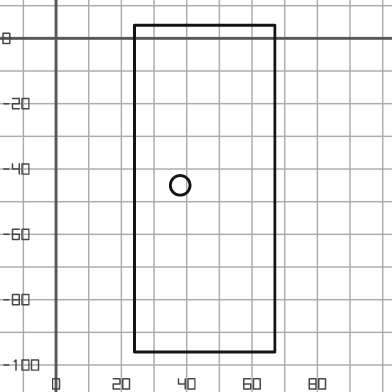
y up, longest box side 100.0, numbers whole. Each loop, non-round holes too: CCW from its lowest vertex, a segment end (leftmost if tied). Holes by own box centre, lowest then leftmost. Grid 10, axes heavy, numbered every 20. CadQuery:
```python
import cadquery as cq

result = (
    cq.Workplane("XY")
    .moveTo(24.0, -96.0)
    .lineTo(67.0, -96.0)
    .lineTo(67.0, 4.0)
    .lineTo(24.0, 4.0)
    .close()
    .moveTo(38.0, -45.0)
    .circle(3.0)
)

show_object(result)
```